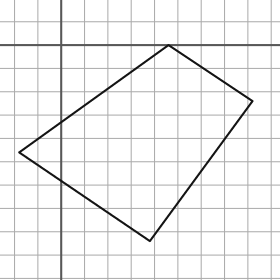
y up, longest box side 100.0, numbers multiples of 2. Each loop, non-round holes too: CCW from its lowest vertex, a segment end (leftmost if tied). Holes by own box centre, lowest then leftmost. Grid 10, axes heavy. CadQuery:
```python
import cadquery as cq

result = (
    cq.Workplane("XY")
    .moveTo(38.0, -84.0)
    .lineTo(82.0, -24.0)
    .lineTo(46.0, 0.0)
    .lineTo(-18.0, -46.0)
    .close()
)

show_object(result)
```